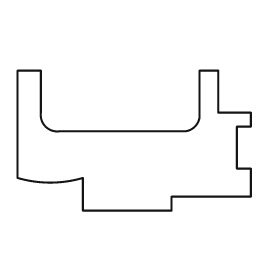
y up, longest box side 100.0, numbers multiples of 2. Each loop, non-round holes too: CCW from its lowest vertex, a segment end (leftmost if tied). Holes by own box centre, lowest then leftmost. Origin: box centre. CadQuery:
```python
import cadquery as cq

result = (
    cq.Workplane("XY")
    .moveTo(-22.0, -30.0)
    .lineTo(16.0, -30.0)
    .lineTo(16.0, -24.0)
    .lineTo(50.0, -24.0)
    .lineTo(50.0, -12.0)
    .lineTo(44.0, -12.0)
    .lineTo(44.0, 6.0)
    .lineTo(50.0, 6.0)
    .lineTo(50.0, 12.0)
    .lineTo(36.0, 12.0)
    .lineTo(36.0, 30.0)
    .lineTo(28.0, 30.0)
    .lineTo(28.0, 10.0)
    .threePointArc((26.0, 6.0), (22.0, 4.0))
    .lineTo(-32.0, 4.0)
    .threePointArc((-38.0, 6.0), (-40.0, 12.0))
    .lineTo(-40.0, 30.0)
    .lineTo(-50.0, 30.0)
    .lineTo(-50.0, -16.0)
    .threePointArc((-36.0, -18.0), (-22.0, -16.0))
    .close()
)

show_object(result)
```